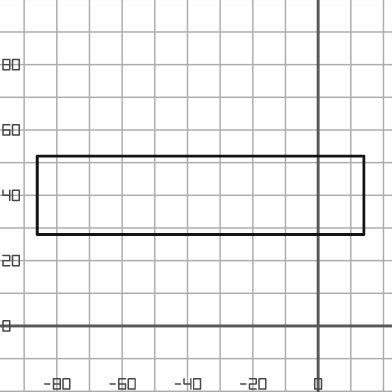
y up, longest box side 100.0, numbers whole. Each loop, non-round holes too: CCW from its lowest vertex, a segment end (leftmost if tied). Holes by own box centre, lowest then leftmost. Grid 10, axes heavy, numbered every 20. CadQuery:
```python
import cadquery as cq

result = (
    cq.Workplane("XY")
    .moveTo(-86.0, 28.0)
    .lineTo(14.0, 28.0)
    .lineTo(14.0, 52.0)
    .lineTo(-86.0, 52.0)
    .close()
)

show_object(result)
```